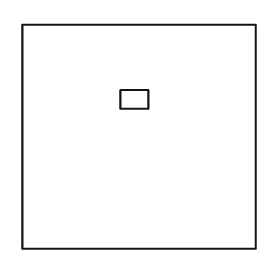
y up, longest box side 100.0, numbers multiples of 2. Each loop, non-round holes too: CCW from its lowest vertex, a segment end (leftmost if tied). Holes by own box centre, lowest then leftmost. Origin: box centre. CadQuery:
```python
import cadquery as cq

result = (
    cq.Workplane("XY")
    .moveTo(-50.0, -48.0)
    .lineTo(50.0, -48.0)
    .lineTo(50.0, 48.0)
    .lineTo(-50.0, 48.0)
    .close()
    .moveTo(-8.0, 12.0)
    .lineTo(4.0, 12.0)
    .lineTo(4.0, 20.0)
    .lineTo(-8.0, 20.0)
    .close()
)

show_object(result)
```